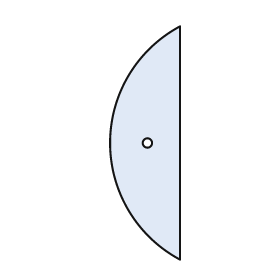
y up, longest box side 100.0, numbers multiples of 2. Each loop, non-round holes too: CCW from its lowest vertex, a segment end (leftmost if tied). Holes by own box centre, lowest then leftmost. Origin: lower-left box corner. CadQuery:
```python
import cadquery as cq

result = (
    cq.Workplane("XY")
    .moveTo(30.0, 0.0)
    .lineTo(30.0, 100.0)
    .threePointArc((0.0, 50.0), (30.0, 0.0))
    .close()
    .moveTo(16.0, 50.0)
    .circle(2.0)
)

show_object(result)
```